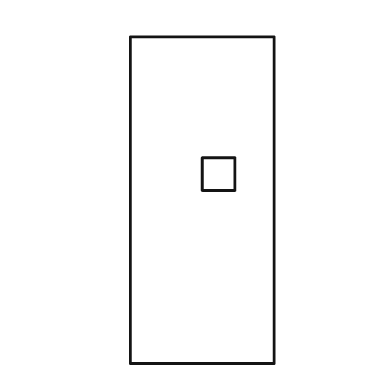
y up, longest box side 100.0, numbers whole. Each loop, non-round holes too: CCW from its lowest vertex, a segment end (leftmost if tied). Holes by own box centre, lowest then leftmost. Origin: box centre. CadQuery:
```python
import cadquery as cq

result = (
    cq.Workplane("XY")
    .moveTo(-22.0, -50.0)
    .lineTo(22.0, -50.0)
    .lineTo(22.0, 50.0)
    .lineTo(-22.0, 50.0)
    .close()
    .moveTo(0.0, 3.0)
    .lineTo(10.0, 3.0)
    .lineTo(10.0, 13.0)
    .lineTo(0.0, 13.0)
    .close()
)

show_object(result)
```